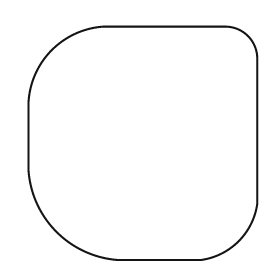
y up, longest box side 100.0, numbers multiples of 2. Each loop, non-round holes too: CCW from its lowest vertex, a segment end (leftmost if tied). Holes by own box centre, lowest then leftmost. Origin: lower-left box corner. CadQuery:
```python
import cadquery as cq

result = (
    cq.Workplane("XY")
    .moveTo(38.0, 0.0)
    .lineTo(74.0, 0.0)
    .threePointArc((90.0, 8.0), (98.0, 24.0))
    .lineTo(98.0, 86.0)
    .threePointArc((94.0, 96.0), (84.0, 100.0))
    .lineTo(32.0, 100.0)
    .threePointArc((10.0, 90.0), (0.0, 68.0))
    .lineTo(0.0, 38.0)
    .threePointArc((12.0, 12.0), (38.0, 0.0))
    .close()
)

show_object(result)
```